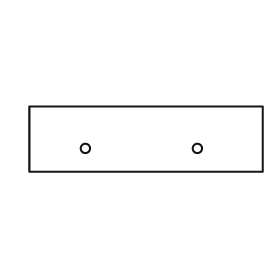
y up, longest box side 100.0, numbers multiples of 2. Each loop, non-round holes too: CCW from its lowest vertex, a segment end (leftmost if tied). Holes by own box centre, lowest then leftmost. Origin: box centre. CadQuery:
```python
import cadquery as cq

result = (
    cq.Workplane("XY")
    .moveTo(-50.0, -14.0)
    .lineTo(50.0, -14.0)
    .lineTo(50.0, 14.0)
    .lineTo(-50.0, 14.0)
    .close()
    .moveTo(-26.0, -4.0)
    .circle(2.0)
    .moveTo(22.0, -4.0)
    .circle(2.0)
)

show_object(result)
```